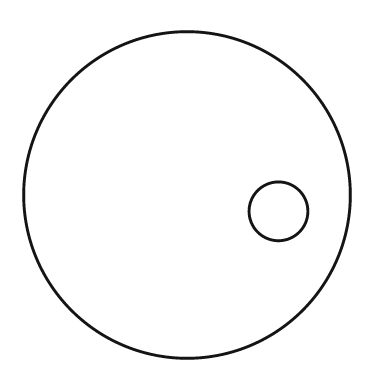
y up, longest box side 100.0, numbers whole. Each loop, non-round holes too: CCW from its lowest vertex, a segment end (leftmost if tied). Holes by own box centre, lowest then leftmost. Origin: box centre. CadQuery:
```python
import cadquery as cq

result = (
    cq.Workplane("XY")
    .moveTo(0.0, 0.0)
    .circle(50.0)
    .moveTo(28.0, -5.0)
    .circle(9.0)
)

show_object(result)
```